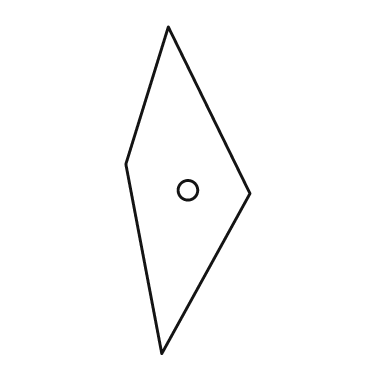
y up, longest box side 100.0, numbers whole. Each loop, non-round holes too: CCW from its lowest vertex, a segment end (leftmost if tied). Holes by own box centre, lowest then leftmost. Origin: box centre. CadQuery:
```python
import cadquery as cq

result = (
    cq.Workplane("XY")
    .moveTo(-8.0, -50.0)
    .lineTo(19.0, -1.0)
    .lineTo(-6.0, 50.0)
    .lineTo(-19.0, 8.0)
    .close()
    .moveTo(0.0, 0.0)
    .circle(3.0)
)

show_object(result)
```